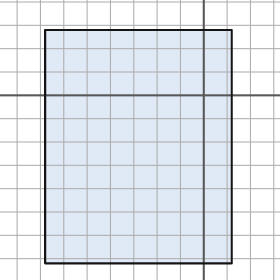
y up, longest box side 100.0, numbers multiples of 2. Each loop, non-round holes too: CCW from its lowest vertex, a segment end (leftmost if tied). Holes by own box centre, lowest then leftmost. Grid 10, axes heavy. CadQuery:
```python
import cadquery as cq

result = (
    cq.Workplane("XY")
    .moveTo(-68.0, -72.0)
    .lineTo(12.0, -72.0)
    .lineTo(12.0, 28.0)
    .lineTo(-68.0, 28.0)
    .close()
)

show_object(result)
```